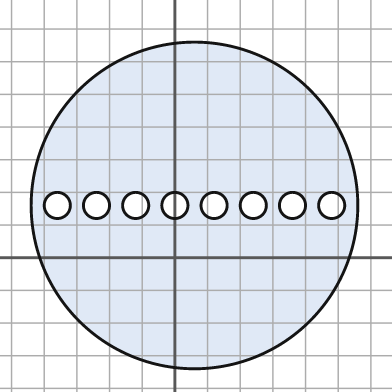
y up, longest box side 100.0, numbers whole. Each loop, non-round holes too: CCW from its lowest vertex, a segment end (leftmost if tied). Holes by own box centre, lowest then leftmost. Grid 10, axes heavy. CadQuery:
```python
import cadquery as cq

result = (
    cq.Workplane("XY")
    .moveTo(6.0, 16.0)
    .circle(50.0)
    .moveTo(-36.0, 16.0)
    .circle(4.0)
    .moveTo(-24.0, 16.0)
    .circle(4.0)
    .moveTo(-12.0, 16.0)
    .circle(4.0)
    .moveTo(0.0, 16.0)
    .circle(4.0)
    .moveTo(12.0, 16.0)
    .circle(4.0)
    .moveTo(24.0, 16.0)
    .circle(4.0)
    .moveTo(36.0, 16.0)
    .circle(4.0)
    .moveTo(48.0, 16.0)
    .circle(4.0)
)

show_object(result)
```